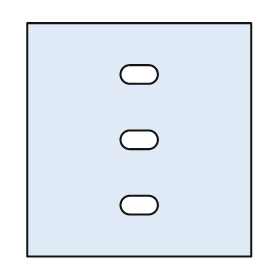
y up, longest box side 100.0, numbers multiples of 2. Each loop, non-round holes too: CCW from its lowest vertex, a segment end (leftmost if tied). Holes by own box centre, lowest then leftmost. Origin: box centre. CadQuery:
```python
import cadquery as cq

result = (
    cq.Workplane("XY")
    .moveTo(-48.0, -50.0)
    .lineTo(48.0, -50.0)
    .lineTo(48.0, 50.0)
    .lineTo(-48.0, 50.0)
    .close()
    .moveTo(-4.0, -32.0)
    .lineTo(4.0, -32.0)
    .threePointArc((8.0, -28.0), (4.0, -24.0))
    .lineTo(-4.0, -24.0)
    .threePointArc((-8.0, -28.0), (-4.0, -32.0))
    .close()
    .moveTo(-4.0, -4.0)
    .lineTo(4.0, -4.0)
    .threePointArc((8.0, 0.0), (4.0, 4.0))
    .lineTo(-4.0, 4.0)
    .threePointArc((-8.0, 0.0), (-4.0, -4.0))
    .close()
    .moveTo(-4.0, 24.0)
    .lineTo(4.0, 24.0)
    .threePointArc((8.0, 28.0), (4.0, 32.0))
    .lineTo(-4.0, 32.0)
    .threePointArc((-8.0, 28.0), (-4.0, 24.0))
    .close()
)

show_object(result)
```